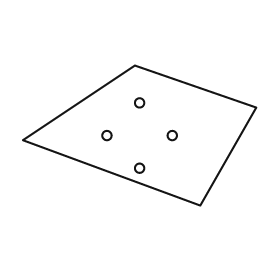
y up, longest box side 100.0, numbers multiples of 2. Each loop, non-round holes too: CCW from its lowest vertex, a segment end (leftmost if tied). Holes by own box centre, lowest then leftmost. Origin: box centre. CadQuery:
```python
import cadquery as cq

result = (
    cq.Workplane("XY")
    .moveTo(26.0, -30.0)
    .lineTo(50.0, 12.0)
    .lineTo(-2.0, 30.0)
    .lineTo(-50.0, -2.0)
    .close()
    .moveTo(0.0, -14.0)
    .circle(2.0)
    .moveTo(-14.0, 0.0)
    .circle(2.0)
    .moveTo(14.0, 0.0)
    .circle(2.0)
    .moveTo(0.0, 14.0)
    .circle(2.0)
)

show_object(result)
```